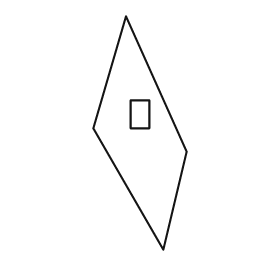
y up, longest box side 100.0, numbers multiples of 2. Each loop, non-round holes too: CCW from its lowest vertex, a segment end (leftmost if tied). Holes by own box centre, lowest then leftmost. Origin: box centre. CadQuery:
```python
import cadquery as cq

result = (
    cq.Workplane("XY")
    .moveTo(10.0, -50.0)
    .lineTo(20.0, -8.0)
    .lineTo(-6.0, 50.0)
    .lineTo(-20.0, 2.0)
    .close()
    .moveTo(-4.0, 2.0)
    .lineTo(4.0, 2.0)
    .lineTo(4.0, 14.0)
    .lineTo(-4.0, 14.0)
    .close()
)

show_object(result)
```